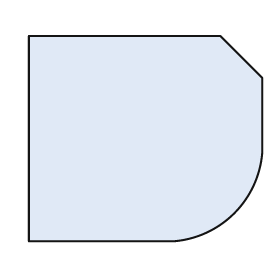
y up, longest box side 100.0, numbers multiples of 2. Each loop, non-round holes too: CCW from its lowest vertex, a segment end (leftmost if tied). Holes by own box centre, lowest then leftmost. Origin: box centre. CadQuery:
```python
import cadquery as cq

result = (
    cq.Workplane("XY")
    .moveTo(-50.0, -44.0)
    .lineTo(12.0, -44.0)
    .threePointArc((38.0, -32.0), (50.0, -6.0))
    .lineTo(50.0, 26.0)
    .lineTo(32.0, 44.0)
    .lineTo(-50.0, 44.0)
    .close()
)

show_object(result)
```